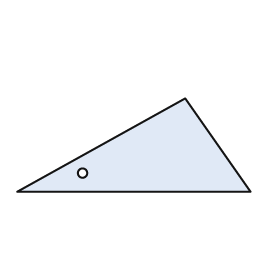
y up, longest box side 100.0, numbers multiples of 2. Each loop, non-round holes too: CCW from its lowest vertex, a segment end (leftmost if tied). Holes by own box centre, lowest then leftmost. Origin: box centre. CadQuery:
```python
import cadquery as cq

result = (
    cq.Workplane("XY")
    .moveTo(-50.0, -20.0)
    .lineTo(50.0, -20.0)
    .lineTo(22.0, 20.0)
    .close()
    .moveTo(-22.0, -12.0)
    .circle(2.0)
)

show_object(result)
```